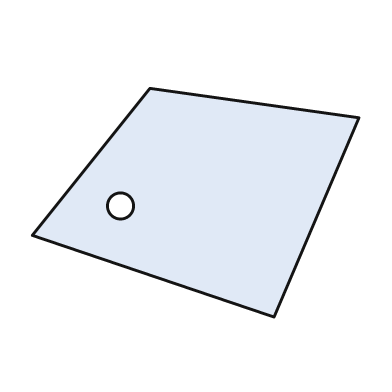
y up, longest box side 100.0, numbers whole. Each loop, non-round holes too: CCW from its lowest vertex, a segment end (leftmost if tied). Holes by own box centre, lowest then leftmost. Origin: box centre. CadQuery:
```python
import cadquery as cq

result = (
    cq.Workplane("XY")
    .moveTo(24.0, -35.0)
    .lineTo(50.0, 26.0)
    .lineTo(-14.0, 35.0)
    .lineTo(-50.0, -10.0)
    .close()
    .moveTo(-23.0, -1.0)
    .circle(4.0)
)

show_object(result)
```